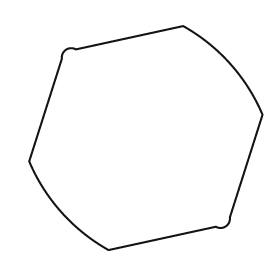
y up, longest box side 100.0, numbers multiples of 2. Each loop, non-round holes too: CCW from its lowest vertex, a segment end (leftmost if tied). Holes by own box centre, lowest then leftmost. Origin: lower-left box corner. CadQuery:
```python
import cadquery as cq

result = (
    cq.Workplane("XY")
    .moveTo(34.0, 0.0)
    .lineTo(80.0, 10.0)
    .threePointArc((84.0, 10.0), (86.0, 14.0))
    .lineTo(100.0, 58.0)
    .threePointArc((86.0, 80.0), (66.0, 96.0))
    .lineTo(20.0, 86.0)
    .threePointArc((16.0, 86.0), (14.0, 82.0))
    .lineTo(0.0, 38.0)
    .threePointArc((14.0, 16.0), (34.0, 0.0))
    .close()
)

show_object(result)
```